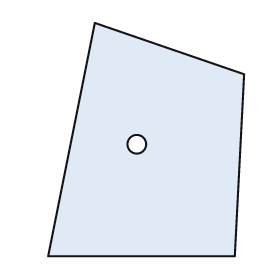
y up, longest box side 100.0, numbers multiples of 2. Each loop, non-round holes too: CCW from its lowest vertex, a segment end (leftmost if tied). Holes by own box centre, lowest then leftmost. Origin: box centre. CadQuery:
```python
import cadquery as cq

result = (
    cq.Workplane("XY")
    .moveTo(-42.0, -50.0)
    .lineTo(38.0, -50.0)
    .lineTo(42.0, 28.0)
    .lineTo(-22.0, 50.0)
    .close()
    .moveTo(-4.0, -2.0)
    .circle(4.0)
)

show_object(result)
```